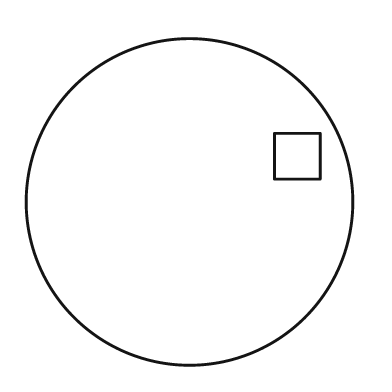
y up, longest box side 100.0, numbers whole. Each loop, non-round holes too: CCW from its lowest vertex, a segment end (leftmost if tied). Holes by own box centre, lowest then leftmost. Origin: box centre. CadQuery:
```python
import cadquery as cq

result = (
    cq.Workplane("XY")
    .moveTo(0.0, 0.0)
    .circle(50.0)
    .moveTo(26.0, 7.0)
    .lineTo(40.0, 7.0)
    .lineTo(40.0, 21.0)
    .lineTo(26.0, 21.0)
    .close()
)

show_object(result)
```